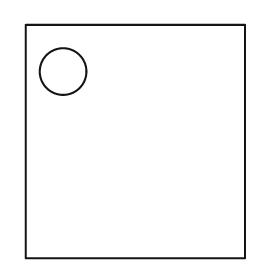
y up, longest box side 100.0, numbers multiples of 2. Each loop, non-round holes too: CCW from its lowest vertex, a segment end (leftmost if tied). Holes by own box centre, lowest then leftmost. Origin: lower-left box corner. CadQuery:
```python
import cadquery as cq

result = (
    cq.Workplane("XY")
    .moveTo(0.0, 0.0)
    .lineTo(94.0, 0.0)
    .lineTo(94.0, 100.0)
    .lineTo(0.0, 100.0)
    .close()
    .moveTo(16.0, 80.0)
    .circle(10.0)
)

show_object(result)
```